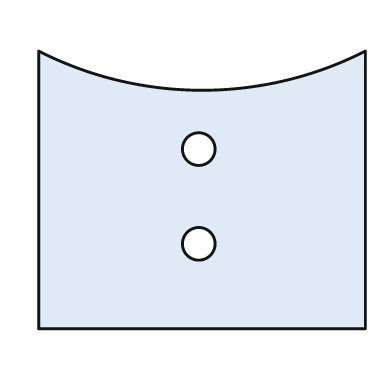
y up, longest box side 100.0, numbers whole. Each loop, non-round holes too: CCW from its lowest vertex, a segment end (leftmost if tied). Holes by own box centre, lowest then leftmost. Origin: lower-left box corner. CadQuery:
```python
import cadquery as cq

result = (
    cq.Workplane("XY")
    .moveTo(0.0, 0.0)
    .lineTo(100.0, 0.0)
    .lineTo(100.0, 85.0)
    .threePointArc((50.0, 73.0), (0.0, 85.0))
    .close()
    .moveTo(49.0, 26.0)
    .circle(5.0)
    .moveTo(49.0, 55.0)
    .circle(5.0)
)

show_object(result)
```